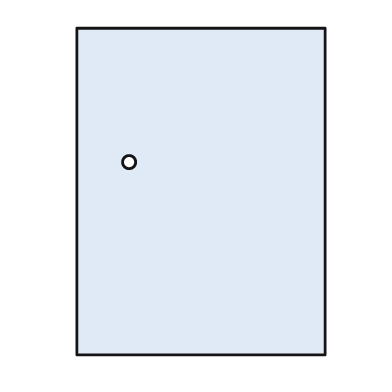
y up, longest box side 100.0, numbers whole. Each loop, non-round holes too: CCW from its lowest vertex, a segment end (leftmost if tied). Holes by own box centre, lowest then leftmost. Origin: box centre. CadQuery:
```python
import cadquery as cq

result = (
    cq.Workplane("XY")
    .moveTo(-38.0, -50.0)
    .lineTo(38.0, -50.0)
    .lineTo(38.0, 50.0)
    .lineTo(-38.0, 50.0)
    .close()
    .moveTo(-22.0, 9.0)
    .circle(2.0)
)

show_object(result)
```